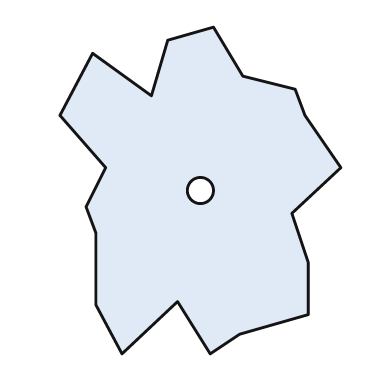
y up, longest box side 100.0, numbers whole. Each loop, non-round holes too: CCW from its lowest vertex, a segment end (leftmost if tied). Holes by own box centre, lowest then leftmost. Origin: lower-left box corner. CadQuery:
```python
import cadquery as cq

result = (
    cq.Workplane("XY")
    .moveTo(19.0, 0.0)
    .lineTo(36.0, 16.0)
    .lineTo(46.0, 0.0)
    .lineTo(55.0, 6.0)
    .lineTo(76.0, 12.0)
    .lineTo(76.0, 28.0)
    .lineTo(71.0, 43.0)
    .lineTo(86.0, 57.0)
    .lineTo(75.0, 73.0)
    .lineTo(72.0, 81.0)
    .lineTo(56.0, 85.0)
    .lineTo(47.0, 100.0)
    .lineTo(33.0, 96.0)
    .lineTo(28.0, 79.0)
    .lineTo(10.0, 92.0)
    .lineTo(0.0, 73.0)
    .lineTo(14.0, 57.0)
    .lineTo(8.0, 45.0)
    .lineTo(11.0, 37.0)
    .lineTo(11.0, 15.0)
    .close()
    .moveTo(43.0, 50.0)
    .circle(4.0)
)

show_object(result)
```